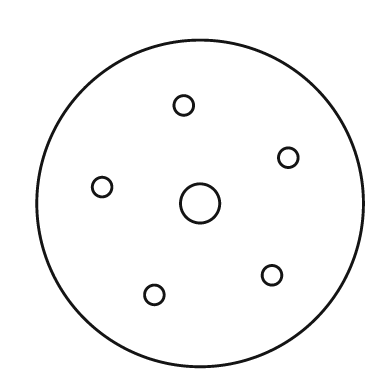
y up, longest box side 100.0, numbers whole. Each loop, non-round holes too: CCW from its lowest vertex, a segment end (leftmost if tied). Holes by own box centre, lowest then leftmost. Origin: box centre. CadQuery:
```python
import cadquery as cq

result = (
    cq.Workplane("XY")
    .moveTo(0.0, 0.0)
    .circle(50.0)
    .moveTo(-14.0, -28.0)
    .circle(3.0)
    .moveTo(22.0, -22.0)
    .circle(3.0)
    .moveTo(0.0, 0.0)
    .circle(6.0)
    .moveTo(-30.0, 5.0)
    .circle(3.0)
    .moveTo(27.0, 14.0)
    .circle(3.0)
    .moveTo(-5.0, 30.0)
    .circle(3.0)
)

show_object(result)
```